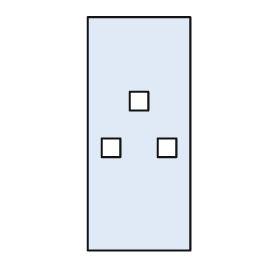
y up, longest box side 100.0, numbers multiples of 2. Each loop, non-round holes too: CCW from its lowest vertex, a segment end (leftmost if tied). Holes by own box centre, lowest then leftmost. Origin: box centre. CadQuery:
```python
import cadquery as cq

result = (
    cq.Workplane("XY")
    .moveTo(-22.0, -50.0)
    .lineTo(22.0, -50.0)
    .lineTo(22.0, 50.0)
    .lineTo(-22.0, 50.0)
    .close()
    .moveTo(-16.0, -10.0)
    .lineTo(-8.0, -10.0)
    .lineTo(-8.0, -2.0)
    .lineTo(-16.0, -2.0)
    .close()
    .moveTo(8.0, -10.0)
    .lineTo(16.0, -10.0)
    .lineTo(16.0, -2.0)
    .lineTo(8.0, -2.0)
    .close()
    .moveTo(-4.0, 10.0)
    .lineTo(4.0, 10.0)
    .lineTo(4.0, 18.0)
    .lineTo(-4.0, 18.0)
    .close()
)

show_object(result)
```